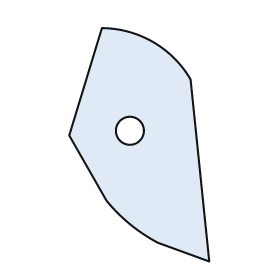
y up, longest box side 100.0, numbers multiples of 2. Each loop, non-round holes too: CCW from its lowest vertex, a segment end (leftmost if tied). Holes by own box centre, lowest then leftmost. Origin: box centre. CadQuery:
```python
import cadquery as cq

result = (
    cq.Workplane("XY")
    .moveTo(30.0, -50.0)
    .lineTo(22.0, 28.0)
    .threePointArc((6.0, 44.0), (-16.0, 50.0))
    .lineTo(-30.0, 4.0)
    .lineTo(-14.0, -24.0)
    .threePointArc((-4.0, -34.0), (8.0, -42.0))
    .close()
    .moveTo(-4.0, 6.0)
    .circle(6.0)
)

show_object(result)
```